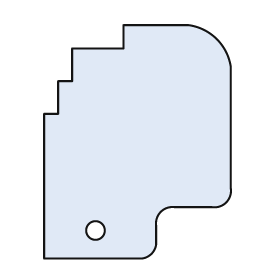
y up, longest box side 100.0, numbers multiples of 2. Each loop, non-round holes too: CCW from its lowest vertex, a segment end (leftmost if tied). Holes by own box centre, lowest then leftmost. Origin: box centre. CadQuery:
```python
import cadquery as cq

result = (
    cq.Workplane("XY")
    .moveTo(-40.0, -50.0)
    .lineTo(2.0, -50.0)
    .threePointArc((6.0, -48.0), (8.0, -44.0))
    .lineTo(8.0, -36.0)
    .threePointArc((10.0, -30.0), (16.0, -28.0))
    .lineTo(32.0, -28.0)
    .threePointArc((38.0, -26.0), (40.0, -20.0))
    .lineTo(40.0, 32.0)
    .threePointArc((34.0, 44.0), (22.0, 50.0))
    .lineTo(-6.0, 50.0)
    .lineTo(-6.0, 40.0)
    .lineTo(-28.0, 40.0)
    .lineTo(-28.0, 26.0)
    .lineTo(-34.0, 26.0)
    .lineTo(-34.0, 12.0)
    .lineTo(-40.0, 12.0)
    .close()
    .moveTo(-18.0, -38.0)
    .circle(4.0)
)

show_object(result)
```